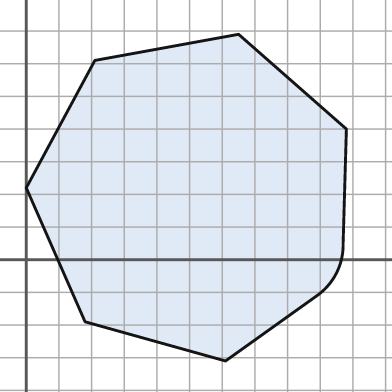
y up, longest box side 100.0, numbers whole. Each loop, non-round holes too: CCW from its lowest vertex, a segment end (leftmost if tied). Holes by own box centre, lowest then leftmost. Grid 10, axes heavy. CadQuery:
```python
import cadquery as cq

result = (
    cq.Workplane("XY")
    .moveTo(61.0, -31.0)
    .lineTo(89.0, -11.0)
    .threePointArc((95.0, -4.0), (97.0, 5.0))
    .lineTo(98.0, 40.0)
    .lineTo(65.0, 69.0)
    .lineTo(21.0, 61.0)
    .lineTo(0.0, 22.0)
    .lineTo(18.0, -19.0)
    .close()
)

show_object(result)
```